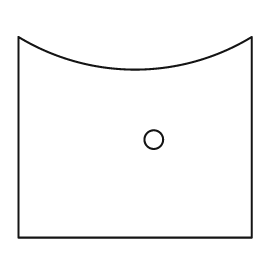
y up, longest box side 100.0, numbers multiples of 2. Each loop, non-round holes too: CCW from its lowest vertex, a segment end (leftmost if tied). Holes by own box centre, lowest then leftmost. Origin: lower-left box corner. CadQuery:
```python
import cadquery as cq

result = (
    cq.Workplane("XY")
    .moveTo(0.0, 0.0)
    .lineTo(100.0, 0.0)
    .lineTo(100.0, 86.0)
    .threePointArc((50.0, 72.0), (0.0, 86.0))
    .close()
    .moveTo(58.0, 42.0)
    .circle(4.0)
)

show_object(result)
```